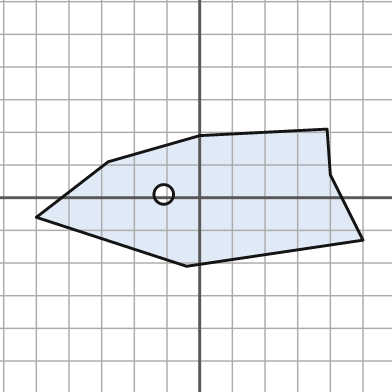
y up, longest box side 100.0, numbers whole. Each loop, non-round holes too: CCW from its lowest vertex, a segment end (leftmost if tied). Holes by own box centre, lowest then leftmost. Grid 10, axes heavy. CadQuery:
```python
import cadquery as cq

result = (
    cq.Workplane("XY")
    .moveTo(-4.0, -21.0)
    .lineTo(50.0, -13.0)
    .lineTo(40.0, 7.0)
    .lineTo(39.0, 21.0)
    .lineTo(0.0, 19.0)
    .lineTo(-28.0, 11.0)
    .lineTo(-50.0, -6.0)
    .close()
    .moveTo(-11.0, 1.0)
    .circle(3.0)
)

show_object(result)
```